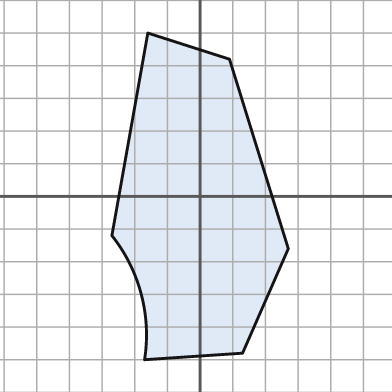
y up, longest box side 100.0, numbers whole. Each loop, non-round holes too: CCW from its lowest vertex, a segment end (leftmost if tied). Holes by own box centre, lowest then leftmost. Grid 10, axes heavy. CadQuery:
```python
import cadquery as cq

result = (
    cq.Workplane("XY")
    .moveTo(-17.0, -50.0)
    .lineTo(13.0, -48.0)
    .lineTo(27.0, -16.0)
    .lineTo(9.0, 42.0)
    .lineTo(-16.0, 50.0)
    .lineTo(-27.0, -12.0)
    .threePointArc((-18.0, -30.0), (-17.0, -50.0))
    .close()
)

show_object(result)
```